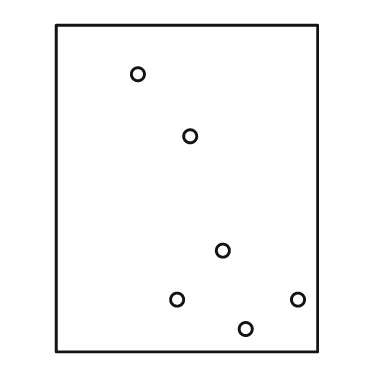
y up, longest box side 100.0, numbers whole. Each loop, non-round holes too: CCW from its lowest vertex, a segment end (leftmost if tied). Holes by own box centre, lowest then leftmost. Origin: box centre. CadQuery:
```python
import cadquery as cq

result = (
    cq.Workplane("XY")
    .moveTo(-40.0, -50.0)
    .lineTo(40.0, -50.0)
    .lineTo(40.0, 50.0)
    .lineTo(-40.0, 50.0)
    .close()
    .moveTo(18.0, -43.0)
    .circle(2.0)
    .moveTo(-3.0, -34.0)
    .circle(2.0)
    .moveTo(34.0, -34.0)
    .circle(2.0)
    .moveTo(11.0, -19.0)
    .circle(2.0)
    .moveTo(1.0, 16.0)
    .circle(2.0)
    .moveTo(-15.0, 35.0)
    .circle(2.0)
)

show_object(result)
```